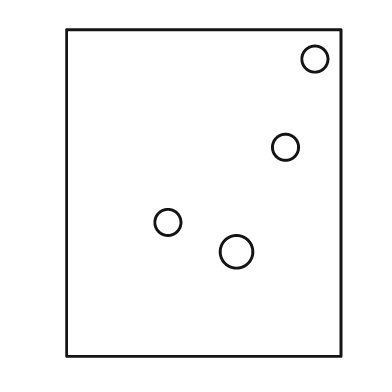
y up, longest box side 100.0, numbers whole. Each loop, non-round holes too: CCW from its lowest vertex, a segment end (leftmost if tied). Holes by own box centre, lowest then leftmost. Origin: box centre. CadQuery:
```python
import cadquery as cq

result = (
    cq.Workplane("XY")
    .moveTo(-42.0, -50.0)
    .lineTo(42.0, -50.0)
    .lineTo(42.0, 50.0)
    .lineTo(-42.0, 50.0)
    .close()
    .moveTo(10.0, -18.0)
    .circle(5.0)
    .moveTo(-11.0, -9.0)
    .circle(4.0)
    .moveTo(25.0, 14.0)
    .circle(4.0)
    .moveTo(34.0, 41.0)
    .circle(4.0)
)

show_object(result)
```